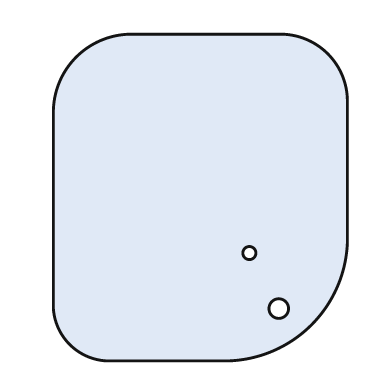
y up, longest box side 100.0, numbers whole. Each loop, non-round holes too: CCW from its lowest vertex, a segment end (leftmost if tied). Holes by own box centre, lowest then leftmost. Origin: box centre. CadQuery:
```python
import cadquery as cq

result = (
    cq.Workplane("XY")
    .moveTo(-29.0, -50.0)
    .lineTo(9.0, -50.0)
    .threePointArc((34.0, -39.0), (45.0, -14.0))
    .lineTo(45.0, 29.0)
    .threePointArc((39.0, 44.0), (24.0, 50.0))
    .lineTo(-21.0, 50.0)
    .threePointArc((-38.0, 43.0), (-45.0, 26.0))
    .lineTo(-45.0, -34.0)
    .threePointArc((-40.0, -45.0), (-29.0, -50.0))
    .close()
    .moveTo(24.0, -34.0)
    .circle(3.0)
    .moveTo(15.0, -17.0)
    .circle(2.0)
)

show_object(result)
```